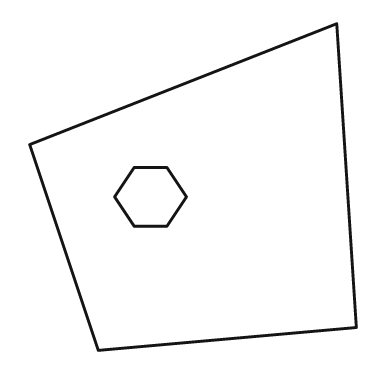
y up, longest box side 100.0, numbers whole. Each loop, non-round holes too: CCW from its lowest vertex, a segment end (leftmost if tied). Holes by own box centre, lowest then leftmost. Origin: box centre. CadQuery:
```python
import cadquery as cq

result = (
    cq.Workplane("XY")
    .moveTo(-29.0, -50.0)
    .lineTo(50.0, -43.0)
    .lineTo(44.0, 50.0)
    .lineTo(-50.0, 13.0)
    .close()
    .moveTo(-18.0, -12.0)
    .lineTo(-8.0, -12.0)
    .lineTo(-2.0, -3.0)
    .lineTo(-8.0, 6.0)
    .lineTo(-18.0, 6.0)
    .lineTo(-24.0, -3.0)
    .close()
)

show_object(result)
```